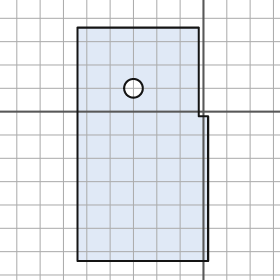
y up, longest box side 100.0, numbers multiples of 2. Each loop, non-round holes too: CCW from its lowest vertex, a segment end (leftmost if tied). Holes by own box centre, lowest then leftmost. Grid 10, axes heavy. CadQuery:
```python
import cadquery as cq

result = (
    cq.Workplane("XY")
    .moveTo(-54.0, -64.0)
    .lineTo(2.0, -64.0)
    .lineTo(2.0, -2.0)
    .lineTo(-2.0, -2.0)
    .lineTo(-2.0, 36.0)
    .lineTo(-54.0, 36.0)
    .close()
    .moveTo(-30.0, 10.0)
    .circle(4.0)
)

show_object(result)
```